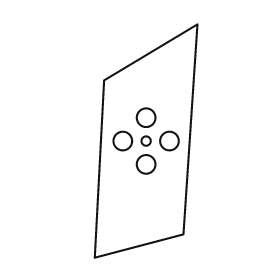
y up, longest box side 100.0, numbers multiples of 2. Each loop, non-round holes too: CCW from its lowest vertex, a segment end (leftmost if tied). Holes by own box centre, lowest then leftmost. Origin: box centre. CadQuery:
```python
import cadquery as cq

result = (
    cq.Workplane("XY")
    .moveTo(-22.0, -50.0)
    .lineTo(16.0, -40.0)
    .lineTo(22.0, 50.0)
    .lineTo(-18.0, 26.0)
    .close()
    .moveTo(0.0, -10.0)
    .circle(4.0)
    .moveTo(-10.0, 0.0)
    .circle(4.0)
    .moveTo(0.0, 0.0)
    .circle(2.0)
    .moveTo(10.0, 0.0)
    .circle(4.0)
    .moveTo(0.0, 10.0)
    .circle(4.0)
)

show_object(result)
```